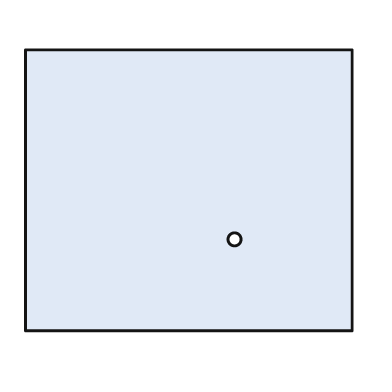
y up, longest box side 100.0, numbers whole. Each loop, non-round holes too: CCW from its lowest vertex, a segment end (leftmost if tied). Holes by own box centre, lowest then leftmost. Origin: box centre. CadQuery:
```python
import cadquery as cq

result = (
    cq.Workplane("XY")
    .moveTo(-50.0, -43.0)
    .lineTo(50.0, -43.0)
    .lineTo(50.0, 43.0)
    .lineTo(-50.0, 43.0)
    .close()
    .moveTo(14.0, -15.0)
    .circle(2.0)
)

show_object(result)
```